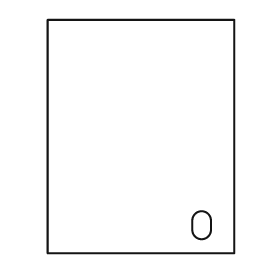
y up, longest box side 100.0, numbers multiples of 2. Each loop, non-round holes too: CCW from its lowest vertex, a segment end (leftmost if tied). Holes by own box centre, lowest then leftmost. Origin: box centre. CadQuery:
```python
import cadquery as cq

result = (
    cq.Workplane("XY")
    .moveTo(-40.0, -50.0)
    .lineTo(40.0, -50.0)
    .lineTo(40.0, 50.0)
    .lineTo(-40.0, 50.0)
    .close()
    .moveTo(22.0, -40.0)
    .threePointArc((26.0, -44.0), (30.0, -40.0))
    .lineTo(30.0, -36.0)
    .threePointArc((26.0, -32.0), (22.0, -36.0))
    .close()
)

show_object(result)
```